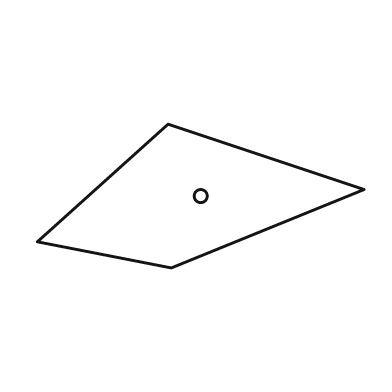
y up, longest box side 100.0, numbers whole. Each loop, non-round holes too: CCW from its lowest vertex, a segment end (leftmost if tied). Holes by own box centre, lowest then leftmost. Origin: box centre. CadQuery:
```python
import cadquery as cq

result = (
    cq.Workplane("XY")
    .moveTo(-9.0, -22.0)
    .lineTo(50.0, 2.0)
    .lineTo(-10.0, 22.0)
    .lineTo(-50.0, -14.0)
    .close()
    .moveTo(0.0, 0.0)
    .circle(2.0)
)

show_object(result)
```